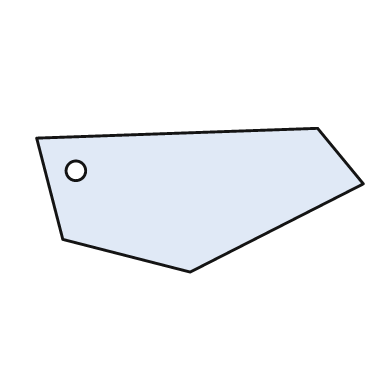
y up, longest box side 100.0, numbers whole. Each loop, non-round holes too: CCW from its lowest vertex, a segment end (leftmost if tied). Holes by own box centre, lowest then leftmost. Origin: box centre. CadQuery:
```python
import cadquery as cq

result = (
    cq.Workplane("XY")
    .moveTo(-3.0, -22.0)
    .lineTo(50.0, 5.0)
    .lineTo(36.0, 22.0)
    .lineTo(-50.0, 19.0)
    .lineTo(-42.0, -12.0)
    .close()
    .moveTo(-38.0, 9.0)
    .circle(3.0)
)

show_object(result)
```